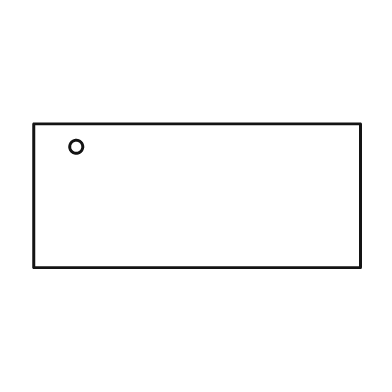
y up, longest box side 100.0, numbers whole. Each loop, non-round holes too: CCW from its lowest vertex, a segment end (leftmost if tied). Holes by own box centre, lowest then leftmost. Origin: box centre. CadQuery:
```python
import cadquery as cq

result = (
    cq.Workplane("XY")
    .moveTo(-50.0, -22.0)
    .lineTo(50.0, -22.0)
    .lineTo(50.0, 22.0)
    .lineTo(-50.0, 22.0)
    .close()
    .moveTo(-37.0, 15.0)
    .circle(2.0)
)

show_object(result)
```